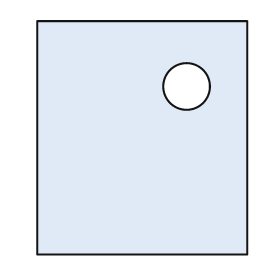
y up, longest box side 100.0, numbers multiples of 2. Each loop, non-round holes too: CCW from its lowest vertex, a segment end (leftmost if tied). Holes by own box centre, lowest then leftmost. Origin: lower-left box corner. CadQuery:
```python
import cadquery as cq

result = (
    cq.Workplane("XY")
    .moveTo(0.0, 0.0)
    .lineTo(90.0, 0.0)
    .lineTo(90.0, 100.0)
    .lineTo(0.0, 100.0)
    .close()
    .moveTo(64.0, 72.0)
    .circle(10.0)
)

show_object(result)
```